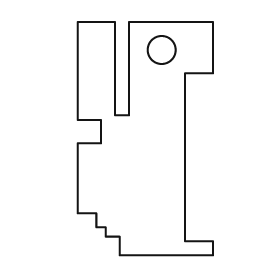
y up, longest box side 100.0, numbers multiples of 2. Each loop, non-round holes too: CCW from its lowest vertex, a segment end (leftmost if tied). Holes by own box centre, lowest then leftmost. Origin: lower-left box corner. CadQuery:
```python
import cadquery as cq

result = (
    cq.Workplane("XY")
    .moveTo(18.0, 0.0)
    .lineTo(58.0, 0.0)
    .lineTo(58.0, 6.0)
    .lineTo(46.0, 6.0)
    .lineTo(46.0, 78.0)
    .lineTo(58.0, 78.0)
    .lineTo(58.0, 100.0)
    .lineTo(22.0, 100.0)
    .lineTo(22.0, 60.0)
    .lineTo(16.0, 60.0)
    .lineTo(16.0, 100.0)
    .lineTo(0.0, 100.0)
    .lineTo(0.0, 58.0)
    .lineTo(10.0, 58.0)
    .lineTo(10.0, 48.0)
    .lineTo(0.0, 48.0)
    .lineTo(0.0, 18.0)
    .lineTo(8.0, 18.0)
    .lineTo(8.0, 12.0)
    .lineTo(12.0, 12.0)
    .lineTo(12.0, 8.0)
    .lineTo(18.0, 8.0)
    .close()
    .moveTo(36.0, 88.0)
    .circle(6.0)
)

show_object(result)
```